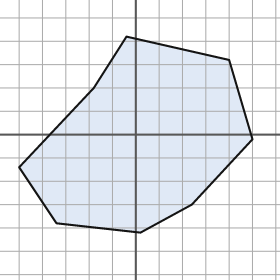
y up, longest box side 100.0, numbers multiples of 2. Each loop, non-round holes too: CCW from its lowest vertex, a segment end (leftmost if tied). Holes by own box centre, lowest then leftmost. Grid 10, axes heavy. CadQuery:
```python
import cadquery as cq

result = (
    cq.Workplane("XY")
    .moveTo(2.0, -42.0)
    .lineTo(24.0, -30.0)
    .lineTo(50.0, -2.0)
    .lineTo(40.0, 32.0)
    .lineTo(-4.0, 42.0)
    .lineTo(-18.0, 20.0)
    .lineTo(-50.0, -14.0)
    .lineTo(-34.0, -38.0)
    .close()
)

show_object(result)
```